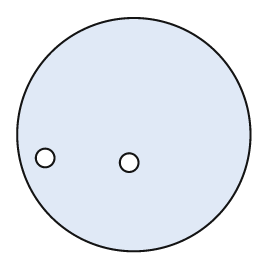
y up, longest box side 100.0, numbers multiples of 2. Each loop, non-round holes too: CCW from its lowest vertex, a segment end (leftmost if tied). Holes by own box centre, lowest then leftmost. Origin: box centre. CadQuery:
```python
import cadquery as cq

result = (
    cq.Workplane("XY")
    .moveTo(0.0, 0.0)
    .circle(50.0)
    .moveTo(-2.0, -12.0)
    .circle(4.0)
    .moveTo(-38.0, -10.0)
    .circle(4.0)
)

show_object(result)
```